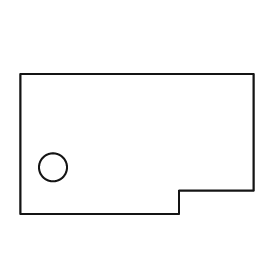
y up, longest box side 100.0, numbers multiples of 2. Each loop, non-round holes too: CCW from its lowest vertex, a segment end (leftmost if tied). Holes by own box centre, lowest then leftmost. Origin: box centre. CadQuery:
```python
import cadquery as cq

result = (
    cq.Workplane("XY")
    .moveTo(-50.0, -30.0)
    .lineTo(18.0, -30.0)
    .lineTo(18.0, -20.0)
    .lineTo(50.0, -20.0)
    .lineTo(50.0, 30.0)
    .lineTo(-50.0, 30.0)
    .close()
    .moveTo(-36.0, -10.0)
    .circle(6.0)
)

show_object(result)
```